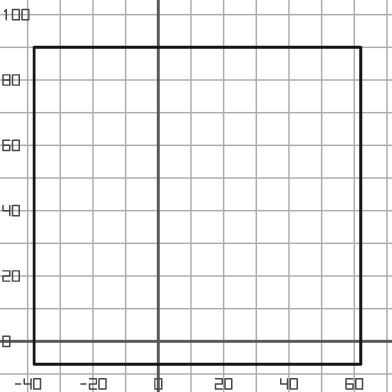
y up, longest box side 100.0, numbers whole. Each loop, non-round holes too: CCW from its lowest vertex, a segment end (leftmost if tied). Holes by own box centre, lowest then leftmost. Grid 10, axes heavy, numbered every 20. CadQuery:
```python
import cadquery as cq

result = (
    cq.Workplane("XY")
    .moveTo(-38.0, -7.0)
    .lineTo(62.0, -7.0)
    .lineTo(62.0, 90.0)
    .lineTo(-38.0, 90.0)
    .close()
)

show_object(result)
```